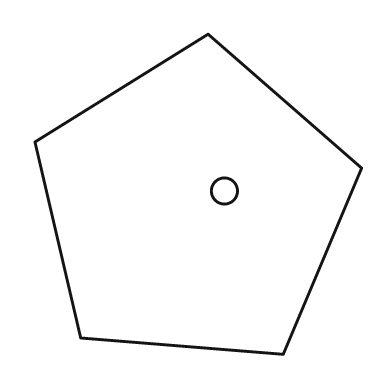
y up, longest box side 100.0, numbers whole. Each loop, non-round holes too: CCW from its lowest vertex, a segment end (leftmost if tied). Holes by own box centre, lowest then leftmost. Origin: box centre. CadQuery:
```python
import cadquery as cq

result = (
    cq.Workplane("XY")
    .moveTo(26.0, -49.0)
    .lineTo(50.0, 8.0)
    .lineTo(3.0, 49.0)
    .lineTo(-50.0, 16.0)
    .lineTo(-36.0, -44.0)
    .close()
    .moveTo(8.0, 1.0)
    .circle(4.0)
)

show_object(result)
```